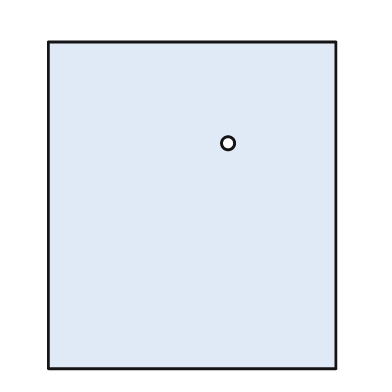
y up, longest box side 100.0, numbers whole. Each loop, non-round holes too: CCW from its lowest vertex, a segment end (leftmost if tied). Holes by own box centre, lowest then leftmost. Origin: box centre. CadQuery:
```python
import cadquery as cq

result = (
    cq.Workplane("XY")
    .moveTo(-44.0, -50.0)
    .lineTo(44.0, -50.0)
    .lineTo(44.0, 50.0)
    .lineTo(-44.0, 50.0)
    .close()
    .moveTo(11.0, 19.0)
    .circle(2.0)
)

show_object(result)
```